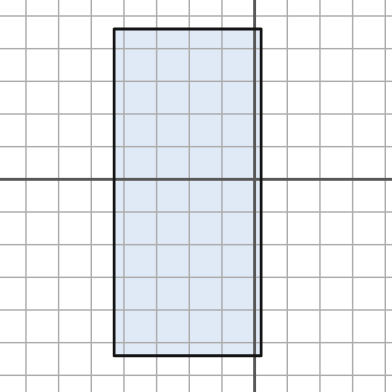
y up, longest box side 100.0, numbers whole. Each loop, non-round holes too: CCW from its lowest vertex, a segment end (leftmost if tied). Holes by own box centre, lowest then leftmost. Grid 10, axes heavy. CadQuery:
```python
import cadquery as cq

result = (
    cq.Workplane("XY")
    .moveTo(-43.0, -54.0)
    .lineTo(2.0, -54.0)
    .lineTo(2.0, 46.0)
    .lineTo(-43.0, 46.0)
    .close()
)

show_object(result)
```